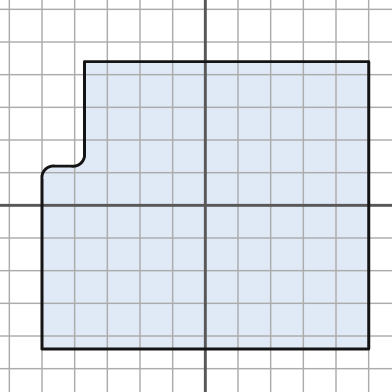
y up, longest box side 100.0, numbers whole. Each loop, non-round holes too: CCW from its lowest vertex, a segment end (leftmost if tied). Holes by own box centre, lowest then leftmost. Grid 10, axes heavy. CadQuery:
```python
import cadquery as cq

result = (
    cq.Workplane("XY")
    .moveTo(-50.0, -44.0)
    .lineTo(50.0, -44.0)
    .lineTo(50.0, 44.0)
    .lineTo(-37.0, 44.0)
    .lineTo(-37.0, 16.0)
    .threePointArc((-38.0, 13.0), (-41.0, 12.0))
    .lineTo(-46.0, 12.0)
    .threePointArc((-49.0, 11.0), (-50.0, 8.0))
    .close()
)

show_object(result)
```